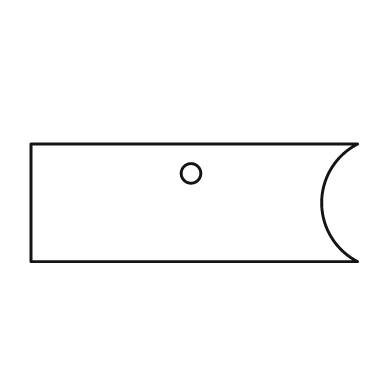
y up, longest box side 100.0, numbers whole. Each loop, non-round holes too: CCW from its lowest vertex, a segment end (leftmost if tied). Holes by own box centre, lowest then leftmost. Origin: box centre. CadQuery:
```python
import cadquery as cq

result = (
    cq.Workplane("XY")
    .moveTo(-50.0, -18.0)
    .lineTo(50.0, -18.0)
    .threePointArc((39.0, 0.0), (50.0, 18.0))
    .lineTo(-50.0, 18.0)
    .close()
    .moveTo(-1.0, 9.0)
    .circle(3.0)
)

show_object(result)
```